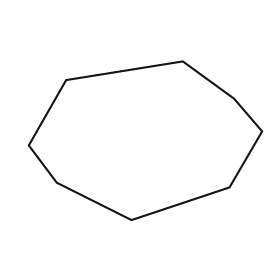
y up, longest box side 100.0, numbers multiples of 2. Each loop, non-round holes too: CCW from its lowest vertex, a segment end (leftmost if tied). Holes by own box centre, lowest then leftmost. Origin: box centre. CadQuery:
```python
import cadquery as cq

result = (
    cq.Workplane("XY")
    .moveTo(-6.0, -34.0)
    .lineTo(36.0, -20.0)
    .lineTo(50.0, 4.0)
    .lineTo(38.0, 18.0)
    .lineTo(16.0, 34.0)
    .lineTo(-34.0, 26.0)
    .lineTo(-50.0, -2.0)
    .lineTo(-38.0, -18.0)
    .close()
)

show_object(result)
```